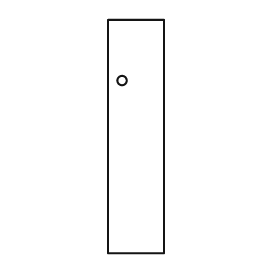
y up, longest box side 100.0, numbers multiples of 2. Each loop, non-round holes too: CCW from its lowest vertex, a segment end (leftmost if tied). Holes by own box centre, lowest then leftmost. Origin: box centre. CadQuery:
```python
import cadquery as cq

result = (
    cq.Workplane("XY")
    .moveTo(-12.0, -50.0)
    .lineTo(12.0, -50.0)
    .lineTo(12.0, 50.0)
    .lineTo(-12.0, 50.0)
    .close()
    .moveTo(-6.0, 24.0)
    .circle(2.0)
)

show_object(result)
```